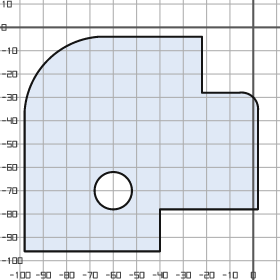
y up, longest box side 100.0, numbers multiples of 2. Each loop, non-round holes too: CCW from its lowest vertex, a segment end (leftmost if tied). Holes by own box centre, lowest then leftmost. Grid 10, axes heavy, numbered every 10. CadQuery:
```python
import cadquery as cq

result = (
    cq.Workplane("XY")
    .moveTo(-98.0, -96.0)
    .lineTo(-40.0, -96.0)
    .lineTo(-40.0, -78.0)
    .lineTo(2.0, -78.0)
    .lineTo(2.0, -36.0)
    .threePointArc((0.0, -30.0), (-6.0, -28.0))
    .lineTo(-22.0, -28.0)
    .lineTo(-22.0, -4.0)
    .lineTo(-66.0, -4.0)
    .threePointArc((-88.0, -14.0), (-98.0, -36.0))
    .close()
    .moveTo(-60.0, -70.0)
    .circle(8.0)
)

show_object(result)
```